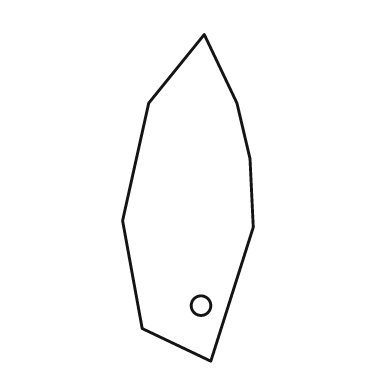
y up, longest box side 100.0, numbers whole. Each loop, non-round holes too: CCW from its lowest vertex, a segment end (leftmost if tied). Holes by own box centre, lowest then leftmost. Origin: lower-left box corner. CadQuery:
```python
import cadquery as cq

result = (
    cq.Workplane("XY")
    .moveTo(27.0, 0.0)
    .lineTo(40.0, 41.0)
    .lineTo(39.0, 62.0)
    .lineTo(35.0, 79.0)
    .lineTo(25.0, 100.0)
    .lineTo(8.0, 79.0)
    .lineTo(0.0, 43.0)
    .lineTo(6.0, 10.0)
    .close()
    .moveTo(24.0, 17.0)
    .circle(3.0)
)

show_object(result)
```